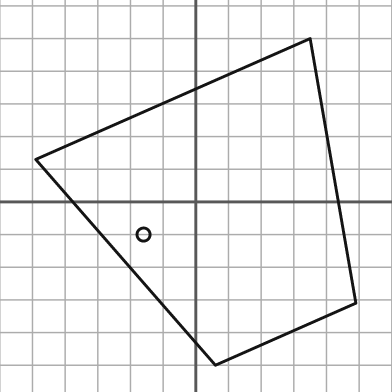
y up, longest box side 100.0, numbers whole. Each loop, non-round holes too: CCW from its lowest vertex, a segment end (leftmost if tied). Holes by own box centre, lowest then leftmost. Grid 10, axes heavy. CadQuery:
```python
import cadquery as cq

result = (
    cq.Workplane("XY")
    .moveTo(6.0, -50.0)
    .lineTo(49.0, -31.0)
    .lineTo(35.0, 50.0)
    .lineTo(-49.0, 13.0)
    .close()
    .moveTo(-16.0, -10.0)
    .circle(2.0)
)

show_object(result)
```